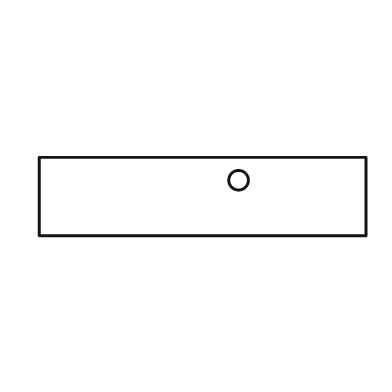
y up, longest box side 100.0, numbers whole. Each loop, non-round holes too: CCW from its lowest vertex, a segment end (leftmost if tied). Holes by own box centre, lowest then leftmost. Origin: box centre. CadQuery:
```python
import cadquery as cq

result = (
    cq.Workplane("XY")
    .moveTo(-50.0, -12.0)
    .lineTo(50.0, -12.0)
    .lineTo(50.0, 12.0)
    .lineTo(-50.0, 12.0)
    .close()
    .moveTo(11.0, 5.0)
    .circle(3.0)
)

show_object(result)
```